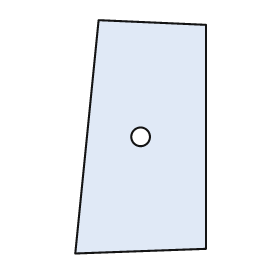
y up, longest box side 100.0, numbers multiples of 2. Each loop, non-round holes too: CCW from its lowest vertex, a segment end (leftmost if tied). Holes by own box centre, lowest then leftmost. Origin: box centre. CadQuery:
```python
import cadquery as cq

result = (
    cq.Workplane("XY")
    .moveTo(-28.0, -50.0)
    .lineTo(28.0, -48.0)
    .lineTo(28.0, 48.0)
    .lineTo(-18.0, 50.0)
    .close()
    .moveTo(0.0, 0.0)
    .circle(4.0)
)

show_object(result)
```